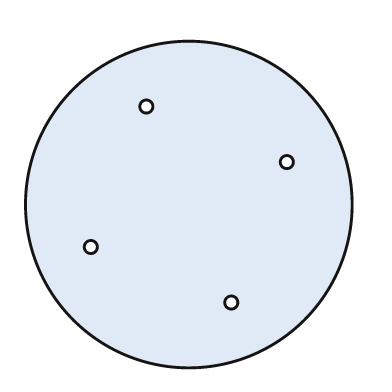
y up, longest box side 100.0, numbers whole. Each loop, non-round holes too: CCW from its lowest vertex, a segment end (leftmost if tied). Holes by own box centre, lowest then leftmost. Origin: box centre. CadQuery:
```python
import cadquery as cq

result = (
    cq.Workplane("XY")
    .moveTo(0.0, 0.0)
    .circle(50.0)
    .moveTo(13.0, -30.0)
    .circle(2.0)
    .moveTo(-30.0, -13.0)
    .circle(2.0)
    .moveTo(30.0, 13.0)
    .circle(2.0)
    .moveTo(-13.0, 30.0)
    .circle(2.0)
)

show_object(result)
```